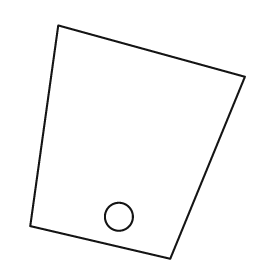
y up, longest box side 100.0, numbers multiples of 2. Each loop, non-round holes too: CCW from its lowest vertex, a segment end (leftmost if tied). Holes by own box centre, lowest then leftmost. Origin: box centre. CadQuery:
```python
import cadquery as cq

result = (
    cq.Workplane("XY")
    .moveTo(14.0, -50.0)
    .lineTo(46.0, 28.0)
    .lineTo(-34.0, 50.0)
    .lineTo(-46.0, -36.0)
    .close()
    .moveTo(-8.0, -32.0)
    .circle(6.0)
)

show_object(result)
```